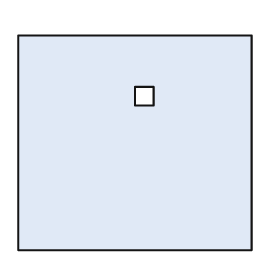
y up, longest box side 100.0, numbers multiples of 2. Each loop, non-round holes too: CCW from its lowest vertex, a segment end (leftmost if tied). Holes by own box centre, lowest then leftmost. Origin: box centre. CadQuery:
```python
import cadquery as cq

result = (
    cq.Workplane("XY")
    .moveTo(-50.0, -46.0)
    .lineTo(50.0, -46.0)
    .lineTo(50.0, 46.0)
    .lineTo(-50.0, 46.0)
    .close()
    .moveTo(0.0, 16.0)
    .lineTo(8.0, 16.0)
    .lineTo(8.0, 24.0)
    .lineTo(0.0, 24.0)
    .close()
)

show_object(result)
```